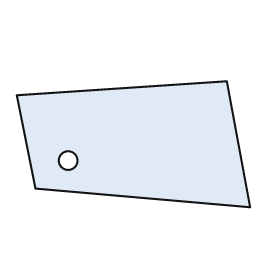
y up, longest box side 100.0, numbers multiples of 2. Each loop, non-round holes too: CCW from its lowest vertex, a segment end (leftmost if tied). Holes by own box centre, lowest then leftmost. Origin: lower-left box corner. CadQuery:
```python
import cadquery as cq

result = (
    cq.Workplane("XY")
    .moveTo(100.0, 0.0)
    .lineTo(90.0, 54.0)
    .lineTo(0.0, 48.0)
    .lineTo(8.0, 8.0)
    .close()
    .moveTo(22.0, 20.0)
    .circle(4.0)
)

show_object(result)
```